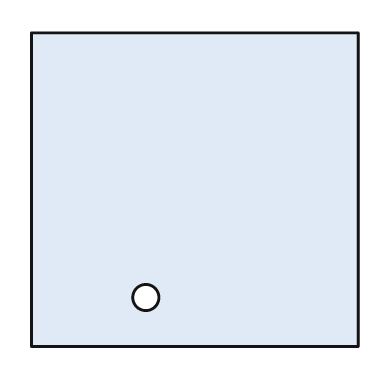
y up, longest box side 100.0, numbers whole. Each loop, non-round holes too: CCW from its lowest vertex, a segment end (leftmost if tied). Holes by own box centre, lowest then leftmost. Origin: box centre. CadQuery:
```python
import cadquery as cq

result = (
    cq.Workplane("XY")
    .moveTo(-50.0, -48.0)
    .lineTo(50.0, -48.0)
    .lineTo(50.0, 48.0)
    .lineTo(-50.0, 48.0)
    .close()
    .moveTo(-15.0, -33.0)
    .circle(4.0)
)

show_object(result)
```